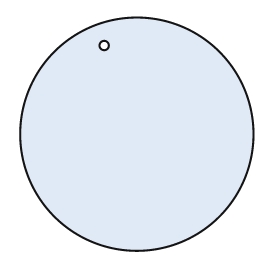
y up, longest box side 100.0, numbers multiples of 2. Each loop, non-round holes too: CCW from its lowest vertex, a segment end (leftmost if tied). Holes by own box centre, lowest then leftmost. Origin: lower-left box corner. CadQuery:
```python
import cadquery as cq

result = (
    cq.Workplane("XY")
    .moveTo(50.0, 50.0)
    .circle(50.0)
    .moveTo(36.0, 88.0)
    .circle(2.0)
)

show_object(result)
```